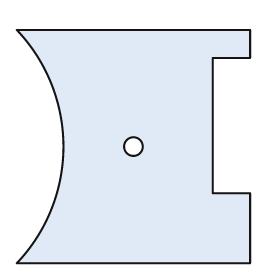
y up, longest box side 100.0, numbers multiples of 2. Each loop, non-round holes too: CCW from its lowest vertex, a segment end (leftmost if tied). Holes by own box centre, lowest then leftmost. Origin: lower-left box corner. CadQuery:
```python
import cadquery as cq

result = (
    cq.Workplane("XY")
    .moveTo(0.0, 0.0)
    .lineTo(100.0, 0.0)
    .lineTo(100.0, 30.0)
    .lineTo(84.0, 30.0)
    .lineTo(84.0, 88.0)
    .lineTo(100.0, 88.0)
    .lineTo(100.0, 100.0)
    .lineTo(0.0, 100.0)
    .threePointArc((20.0, 50.0), (0.0, 0.0))
    .close()
    .moveTo(50.0, 50.0)
    .circle(4.0)
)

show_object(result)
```